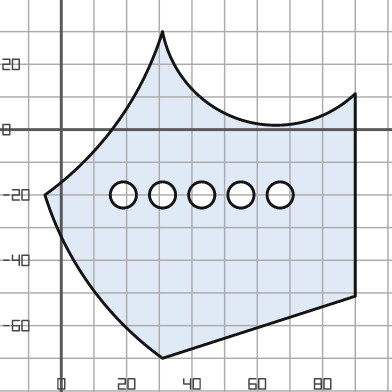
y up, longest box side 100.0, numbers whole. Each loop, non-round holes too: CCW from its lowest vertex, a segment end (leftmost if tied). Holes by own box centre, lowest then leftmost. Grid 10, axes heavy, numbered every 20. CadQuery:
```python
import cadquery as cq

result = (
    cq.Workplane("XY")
    .moveTo(31.0, -70.0)
    .lineTo(90.0, -51.0)
    .lineTo(90.0, 11.0)
    .threePointArc((55.0, 3.0), (31.0, 30.0))
    .threePointArc((17.0, 2.0), (-5.0, -20.0))
    .threePointArc((9.0, -48.0), (31.0, -70.0))
    .close()
    .moveTo(19.0, -20.0)
    .circle(4.0)
    .moveTo(31.0, -20.0)
    .circle(4.0)
    .moveTo(43.0, -20.0)
    .circle(4.0)
    .moveTo(55.0, -20.0)
    .circle(4.0)
    .moveTo(67.0, -20.0)
    .circle(4.0)
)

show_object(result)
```